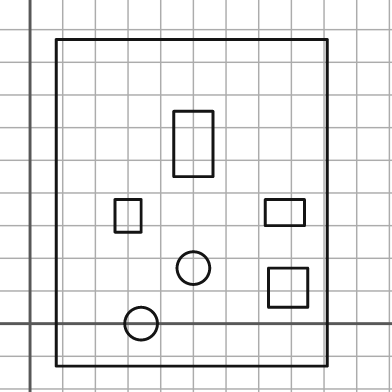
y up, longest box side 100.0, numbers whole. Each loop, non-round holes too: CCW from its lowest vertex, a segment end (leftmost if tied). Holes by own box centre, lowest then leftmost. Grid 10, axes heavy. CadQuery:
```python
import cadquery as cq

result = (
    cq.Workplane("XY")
    .moveTo(8.0, -13.0)
    .lineTo(91.0, -13.0)
    .lineTo(91.0, 87.0)
    .lineTo(8.0, 87.0)
    .close()
    .moveTo(34.0, 0.0)
    .circle(5.0)
    .moveTo(73.0, 5.0)
    .lineTo(85.0, 5.0)
    .lineTo(85.0, 17.0)
    .lineTo(73.0, 17.0)
    .close()
    .moveTo(50.0, 17.0)
    .circle(5.0)
    .moveTo(26.0, 28.0)
    .lineTo(34.0, 28.0)
    .lineTo(34.0, 38.0)
    .lineTo(26.0, 38.0)
    .close()
    .moveTo(72.0, 30.0)
    .lineTo(84.0, 30.0)
    .lineTo(84.0, 38.0)
    .lineTo(72.0, 38.0)
    .close()
    .moveTo(44.0, 45.0)
    .lineTo(56.0, 45.0)
    .lineTo(56.0, 65.0)
    .lineTo(44.0, 65.0)
    .close()
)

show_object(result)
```